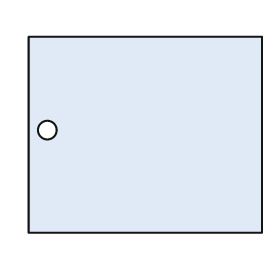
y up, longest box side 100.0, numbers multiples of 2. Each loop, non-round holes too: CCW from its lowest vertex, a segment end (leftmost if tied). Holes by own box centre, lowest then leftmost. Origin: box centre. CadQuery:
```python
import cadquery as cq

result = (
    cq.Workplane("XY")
    .moveTo(-50.0, -42.0)
    .lineTo(50.0, -42.0)
    .lineTo(50.0, 42.0)
    .lineTo(-50.0, 42.0)
    .close()
    .moveTo(-42.0, 2.0)
    .circle(4.0)
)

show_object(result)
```